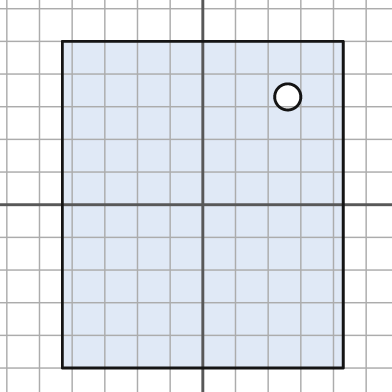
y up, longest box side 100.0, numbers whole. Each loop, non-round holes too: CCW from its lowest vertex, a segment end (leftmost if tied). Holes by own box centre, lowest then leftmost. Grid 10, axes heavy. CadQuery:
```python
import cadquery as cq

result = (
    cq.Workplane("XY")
    .moveTo(-43.0, -50.0)
    .lineTo(43.0, -50.0)
    .lineTo(43.0, 50.0)
    .lineTo(-43.0, 50.0)
    .close()
    .moveTo(26.0, 33.0)
    .circle(4.0)
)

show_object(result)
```